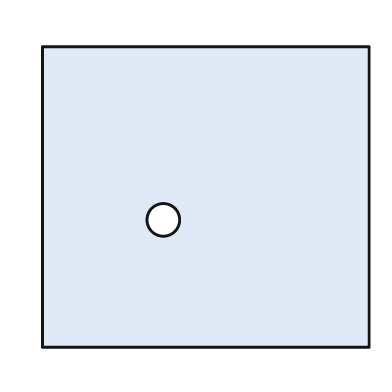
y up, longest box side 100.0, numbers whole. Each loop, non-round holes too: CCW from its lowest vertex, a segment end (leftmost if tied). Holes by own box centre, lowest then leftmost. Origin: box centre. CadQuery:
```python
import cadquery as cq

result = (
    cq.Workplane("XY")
    .moveTo(-50.0, -46.0)
    .lineTo(50.0, -46.0)
    .lineTo(50.0, 46.0)
    .lineTo(-50.0, 46.0)
    .close()
    .moveTo(-13.0, -7.0)
    .circle(5.0)
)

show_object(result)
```